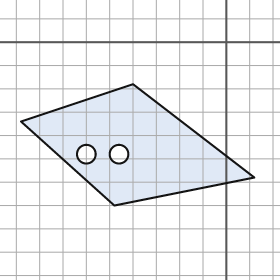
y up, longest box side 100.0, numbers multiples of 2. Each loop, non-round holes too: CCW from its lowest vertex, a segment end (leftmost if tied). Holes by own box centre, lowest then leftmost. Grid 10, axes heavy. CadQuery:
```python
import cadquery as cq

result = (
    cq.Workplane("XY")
    .moveTo(-48.0, -70.0)
    .lineTo(12.0, -58.0)
    .lineTo(-40.0, -18.0)
    .lineTo(-88.0, -34.0)
    .close()
    .moveTo(-60.0, -48.0)
    .circle(4.0)
    .moveTo(-46.0, -48.0)
    .circle(4.0)
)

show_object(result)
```